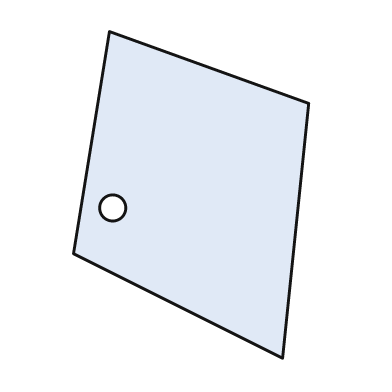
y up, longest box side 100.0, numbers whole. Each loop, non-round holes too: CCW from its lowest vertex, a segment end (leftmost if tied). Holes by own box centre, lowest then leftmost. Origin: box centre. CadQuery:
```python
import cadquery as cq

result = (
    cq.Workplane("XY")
    .moveTo(28.0, -50.0)
    .lineTo(36.0, 28.0)
    .lineTo(-25.0, 50.0)
    .lineTo(-36.0, -18.0)
    .close()
    .moveTo(-24.0, -4.0)
    .circle(4.0)
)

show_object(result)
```